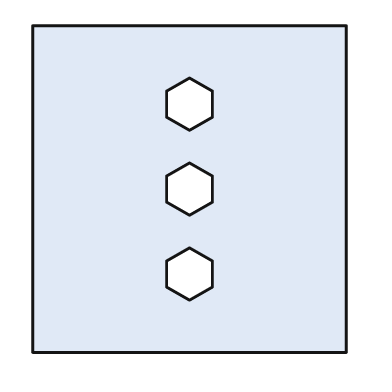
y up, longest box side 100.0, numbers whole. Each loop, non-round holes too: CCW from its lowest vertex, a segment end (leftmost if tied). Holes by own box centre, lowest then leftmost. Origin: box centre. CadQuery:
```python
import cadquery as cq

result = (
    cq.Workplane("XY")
    .moveTo(-48.0, -50.0)
    .lineTo(48.0, -50.0)
    .lineTo(48.0, 50.0)
    .lineTo(-48.0, 50.0)
    .close()
    .moveTo(0.0, -34.0)
    .lineTo(7.0, -30.0)
    .lineTo(7.0, -22.0)
    .lineTo(0.0, -18.0)
    .lineTo(-7.0, -22.0)
    .lineTo(-7.0, -30.0)
    .close()
    .moveTo(0.0, -8.0)
    .lineTo(7.0, -4.0)
    .lineTo(7.0, 4.0)
    .lineTo(0.0, 8.0)
    .lineTo(-7.0, 4.0)
    .lineTo(-7.0, -4.0)
    .close()
    .moveTo(0.0, 18.0)
    .lineTo(7.0, 22.0)
    .lineTo(7.0, 30.0)
    .lineTo(0.0, 34.0)
    .lineTo(-7.0, 30.0)
    .lineTo(-7.0, 22.0)
    .close()
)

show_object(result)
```